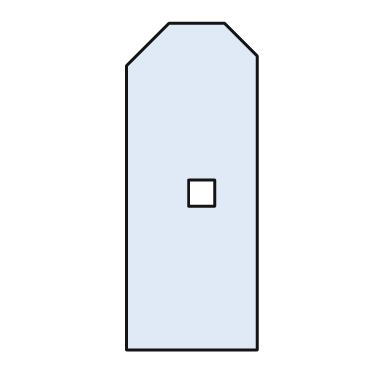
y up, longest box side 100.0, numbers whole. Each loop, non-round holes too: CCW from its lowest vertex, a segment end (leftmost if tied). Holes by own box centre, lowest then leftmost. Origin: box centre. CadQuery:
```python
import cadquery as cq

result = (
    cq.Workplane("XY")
    .moveTo(-20.0, -50.0)
    .lineTo(20.0, -50.0)
    .lineTo(20.0, 40.0)
    .lineTo(10.0, 50.0)
    .lineTo(-7.0, 50.0)
    .lineTo(-20.0, 37.0)
    .close()
    .moveTo(-1.0, -6.0)
    .lineTo(7.0, -6.0)
    .lineTo(7.0, 2.0)
    .lineTo(-1.0, 2.0)
    .close()
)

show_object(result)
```